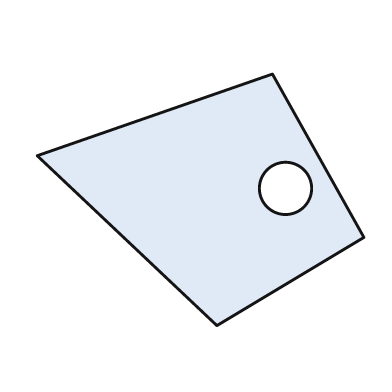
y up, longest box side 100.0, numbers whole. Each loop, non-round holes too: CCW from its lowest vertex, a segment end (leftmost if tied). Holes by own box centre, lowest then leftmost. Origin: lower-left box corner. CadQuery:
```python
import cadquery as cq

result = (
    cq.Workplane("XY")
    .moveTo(55.0, 0.0)
    .lineTo(100.0, 27.0)
    .lineTo(72.0, 77.0)
    .lineTo(0.0, 52.0)
    .close()
    .moveTo(76.0, 42.0)
    .circle(8.0)
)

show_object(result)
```